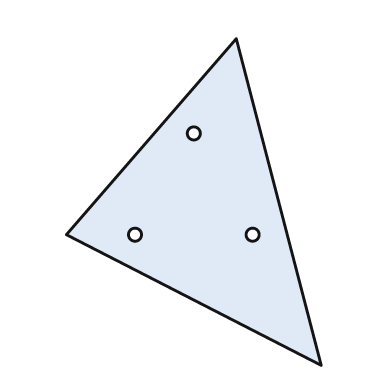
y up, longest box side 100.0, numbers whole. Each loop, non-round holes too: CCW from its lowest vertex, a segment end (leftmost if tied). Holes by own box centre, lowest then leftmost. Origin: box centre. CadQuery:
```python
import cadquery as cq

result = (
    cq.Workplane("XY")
    .moveTo(39.0, -50.0)
    .lineTo(13.0, 50.0)
    .lineTo(-39.0, -10.0)
    .close()
    .moveTo(-18.0, -10.0)
    .circle(2.0)
    .moveTo(18.0, -10.0)
    .circle(2.0)
    .moveTo(0.0, 21.0)
    .circle(2.0)
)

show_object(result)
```